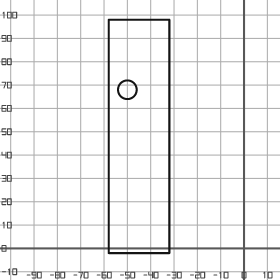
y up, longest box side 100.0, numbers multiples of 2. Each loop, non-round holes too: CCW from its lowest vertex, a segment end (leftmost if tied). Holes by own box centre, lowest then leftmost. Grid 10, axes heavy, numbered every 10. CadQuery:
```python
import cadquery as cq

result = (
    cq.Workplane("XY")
    .moveTo(-58.0, -2.0)
    .lineTo(-32.0, -2.0)
    .lineTo(-32.0, 98.0)
    .lineTo(-58.0, 98.0)
    .close()
    .moveTo(-50.0, 68.0)
    .circle(4.0)
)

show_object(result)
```